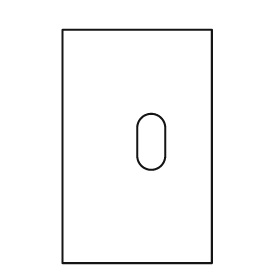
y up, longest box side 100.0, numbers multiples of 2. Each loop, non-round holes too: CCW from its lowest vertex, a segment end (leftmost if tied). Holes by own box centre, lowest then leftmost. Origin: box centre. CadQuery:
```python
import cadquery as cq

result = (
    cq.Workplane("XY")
    .moveTo(-32.0, -50.0)
    .lineTo(32.0, -50.0)
    .lineTo(32.0, 50.0)
    .lineTo(-32.0, 50.0)
    .close()
    .moveTo(0.0, -4.0)
    .threePointArc((6.0, -10.0), (12.0, -4.0))
    .lineTo(12.0, 8.0)
    .threePointArc((6.0, 14.0), (0.0, 8.0))
    .close()
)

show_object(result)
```